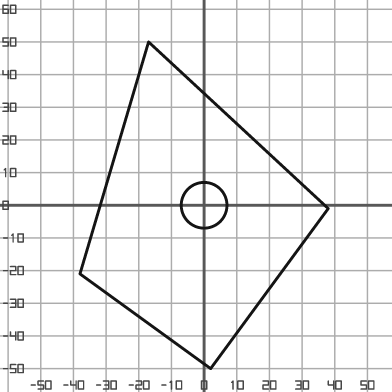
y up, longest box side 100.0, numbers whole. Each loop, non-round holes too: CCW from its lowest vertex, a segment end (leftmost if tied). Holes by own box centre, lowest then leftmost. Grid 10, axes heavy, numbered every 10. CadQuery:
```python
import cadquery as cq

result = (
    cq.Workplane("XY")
    .moveTo(2.0, -50.0)
    .lineTo(38.0, -1.0)
    .lineTo(-17.0, 50.0)
    .lineTo(-38.0, -21.0)
    .close()
    .moveTo(0.0, 0.0)
    .circle(7.0)
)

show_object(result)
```